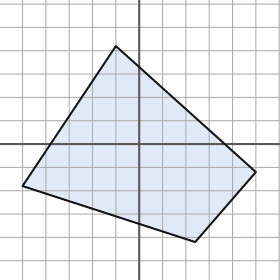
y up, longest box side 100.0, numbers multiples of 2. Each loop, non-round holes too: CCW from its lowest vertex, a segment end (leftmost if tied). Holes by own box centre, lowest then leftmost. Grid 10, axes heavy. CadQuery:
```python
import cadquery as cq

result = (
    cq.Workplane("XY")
    .moveTo(24.0, -42.0)
    .lineTo(50.0, -12.0)
    .lineTo(-10.0, 42.0)
    .lineTo(-50.0, -18.0)
    .close()
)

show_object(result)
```